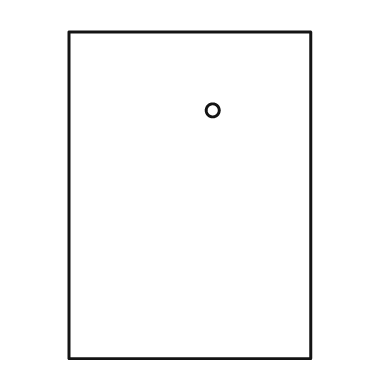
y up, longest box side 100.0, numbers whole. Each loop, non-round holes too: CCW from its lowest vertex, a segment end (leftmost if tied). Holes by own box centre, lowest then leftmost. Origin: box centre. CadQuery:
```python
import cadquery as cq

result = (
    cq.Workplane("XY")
    .moveTo(-37.0, -50.0)
    .lineTo(37.0, -50.0)
    .lineTo(37.0, 50.0)
    .lineTo(-37.0, 50.0)
    .close()
    .moveTo(7.0, 26.0)
    .circle(2.0)
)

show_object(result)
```